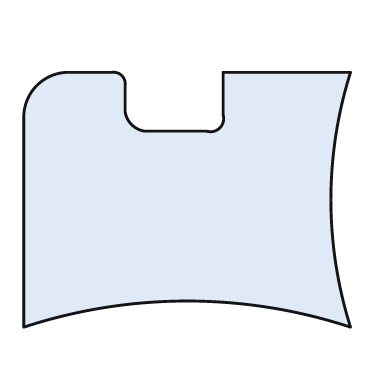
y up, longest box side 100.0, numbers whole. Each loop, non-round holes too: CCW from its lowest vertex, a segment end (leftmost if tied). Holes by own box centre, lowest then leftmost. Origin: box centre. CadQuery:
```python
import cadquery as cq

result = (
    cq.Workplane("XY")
    .moveTo(-50.0, -39.0)
    .threePointArc((0.0, -31.0), (50.0, -39.0))
    .threePointArc((44.0, 0.0), (50.0, 39.0))
    .lineTo(11.0, 39.0)
    .lineTo(11.0, 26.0)
    .threePointArc((10.0, 22.0), (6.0, 21.0))
    .lineTo(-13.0, 21.0)
    .threePointArc((-17.0, 23.0), (-19.0, 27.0))
    .lineTo(-19.0, 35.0)
    .threePointArc((-20.0, 38.0), (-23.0, 39.0))
    .lineTo(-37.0, 39.0)
    .threePointArc((-46.0, 35.0), (-50.0, 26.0))
    .close()
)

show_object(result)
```